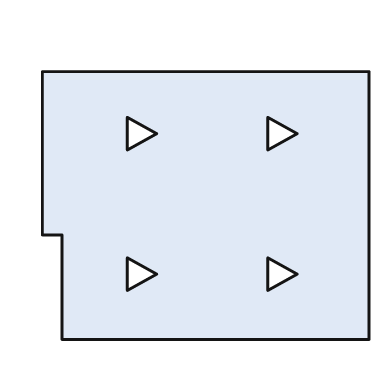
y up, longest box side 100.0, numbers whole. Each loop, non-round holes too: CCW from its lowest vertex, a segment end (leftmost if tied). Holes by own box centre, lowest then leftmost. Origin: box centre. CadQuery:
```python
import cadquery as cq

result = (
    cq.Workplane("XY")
    .moveTo(-44.0, -41.0)
    .lineTo(50.0, -41.0)
    .lineTo(50.0, 41.0)
    .lineTo(-50.0, 41.0)
    .lineTo(-50.0, -9.0)
    .lineTo(-44.0, -9.0)
    .close()
    .moveTo(-24.0, -26.0)
    .lineTo(-15.0, -21.0)
    .lineTo(-24.0, -16.0)
    .close()
    .moveTo(19.0, -26.0)
    .lineTo(28.0, -21.0)
    .lineTo(19.0, -16.0)
    .close()
    .moveTo(-24.0, 17.0)
    .lineTo(-15.0, 22.0)
    .lineTo(-24.0, 27.0)
    .close()
    .moveTo(19.0, 17.0)
    .lineTo(28.0, 22.0)
    .lineTo(19.0, 27.0)
    .close()
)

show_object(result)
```